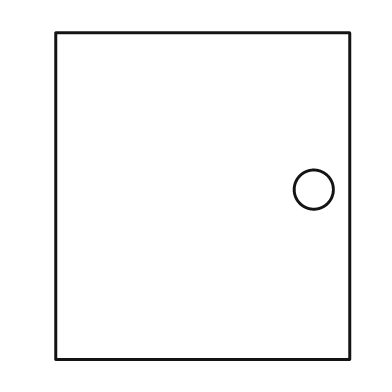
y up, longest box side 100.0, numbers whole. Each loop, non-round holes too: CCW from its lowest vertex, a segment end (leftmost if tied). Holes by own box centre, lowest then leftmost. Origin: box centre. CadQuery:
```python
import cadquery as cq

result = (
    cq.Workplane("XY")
    .moveTo(-45.0, -50.0)
    .lineTo(45.0, -50.0)
    .lineTo(45.0, 50.0)
    .lineTo(-45.0, 50.0)
    .close()
    .moveTo(34.0, 2.0)
    .circle(6.0)
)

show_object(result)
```